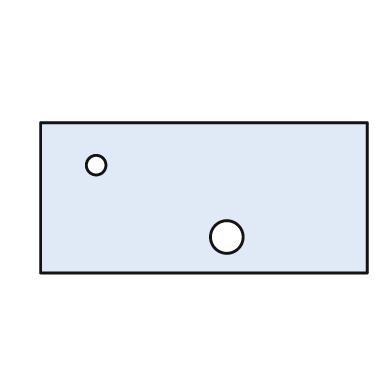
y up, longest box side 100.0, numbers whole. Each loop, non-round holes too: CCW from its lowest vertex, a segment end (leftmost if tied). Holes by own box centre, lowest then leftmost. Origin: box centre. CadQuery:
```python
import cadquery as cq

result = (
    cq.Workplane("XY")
    .moveTo(-50.0, -23.0)
    .lineTo(50.0, -23.0)
    .lineTo(50.0, 23.0)
    .lineTo(-50.0, 23.0)
    .close()
    .moveTo(7.0, -12.0)
    .circle(5.0)
    .moveTo(-33.0, 10.0)
    .circle(3.0)
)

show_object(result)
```